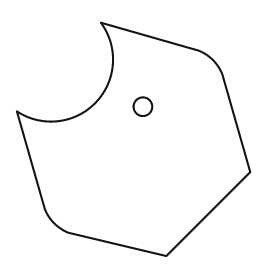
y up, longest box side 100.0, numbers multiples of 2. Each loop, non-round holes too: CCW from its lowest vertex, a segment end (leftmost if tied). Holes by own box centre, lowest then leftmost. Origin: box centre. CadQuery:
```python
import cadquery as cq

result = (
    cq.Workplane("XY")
    .moveTo(14.0, -50.0)
    .lineTo(50.0, -14.0)
    .lineTo(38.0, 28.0)
    .threePointArc((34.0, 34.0), (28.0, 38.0))
    .lineTo(-14.0, 50.0)
    .threePointArc((-16.0, 16.0), (-50.0, 12.0))
    .lineTo(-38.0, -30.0)
    .threePointArc((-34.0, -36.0), (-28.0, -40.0))
    .close()
    .moveTo(4.0, 14.0)
    .circle(4.0)
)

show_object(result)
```